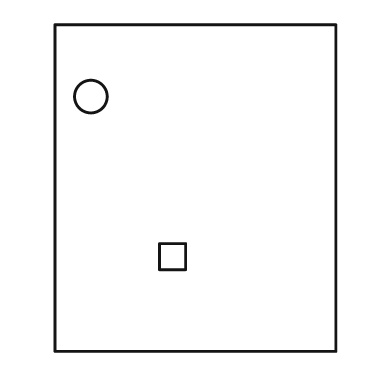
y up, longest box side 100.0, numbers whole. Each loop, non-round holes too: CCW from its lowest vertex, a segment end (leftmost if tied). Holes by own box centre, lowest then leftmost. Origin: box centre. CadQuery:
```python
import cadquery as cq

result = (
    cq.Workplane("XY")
    .moveTo(-43.0, -50.0)
    .lineTo(43.0, -50.0)
    .lineTo(43.0, 50.0)
    .lineTo(-43.0, 50.0)
    .close()
    .moveTo(-11.0, -25.0)
    .lineTo(-3.0, -25.0)
    .lineTo(-3.0, -17.0)
    .lineTo(-11.0, -17.0)
    .close()
    .moveTo(-32.0, 28.0)
    .circle(5.0)
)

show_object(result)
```